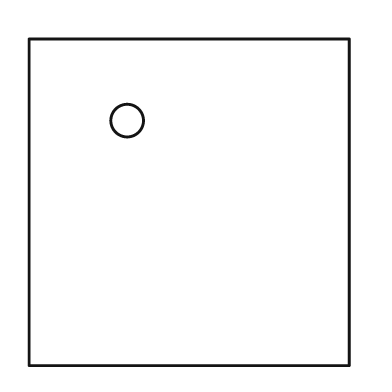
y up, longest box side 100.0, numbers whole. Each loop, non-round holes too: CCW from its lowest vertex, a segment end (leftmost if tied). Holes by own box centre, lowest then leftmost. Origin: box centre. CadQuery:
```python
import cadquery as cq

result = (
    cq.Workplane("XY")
    .moveTo(-49.0, -50.0)
    .lineTo(49.0, -50.0)
    .lineTo(49.0, 50.0)
    .lineTo(-49.0, 50.0)
    .close()
    .moveTo(-19.0, 25.0)
    .circle(5.0)
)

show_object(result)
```